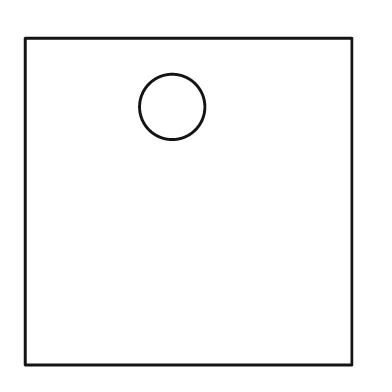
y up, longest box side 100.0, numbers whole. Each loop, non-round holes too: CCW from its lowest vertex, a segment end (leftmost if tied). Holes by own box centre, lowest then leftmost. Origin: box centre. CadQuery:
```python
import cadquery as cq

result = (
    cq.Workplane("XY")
    .moveTo(-50.0, -50.0)
    .lineTo(50.0, -50.0)
    .lineTo(50.0, 50.0)
    .lineTo(-50.0, 50.0)
    .close()
    .moveTo(-5.0, 29.0)
    .circle(10.0)
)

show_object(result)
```